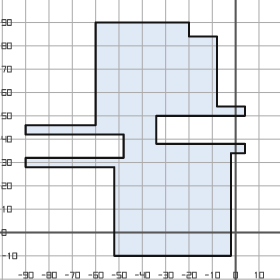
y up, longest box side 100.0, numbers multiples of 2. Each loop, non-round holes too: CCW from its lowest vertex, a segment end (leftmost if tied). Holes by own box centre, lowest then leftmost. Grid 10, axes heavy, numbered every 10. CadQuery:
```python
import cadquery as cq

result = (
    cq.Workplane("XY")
    .moveTo(-52.0, -10.0)
    .lineTo(-2.0, -10.0)
    .lineTo(-2.0, 34.0)
    .lineTo(4.0, 34.0)
    .lineTo(4.0, 38.0)
    .lineTo(-34.0, 38.0)
    .lineTo(-34.0, 50.0)
    .lineTo(4.0, 50.0)
    .lineTo(4.0, 54.0)
    .lineTo(-8.0, 54.0)
    .lineTo(-8.0, 84.0)
    .lineTo(-20.0, 84.0)
    .lineTo(-20.0, 90.0)
    .lineTo(-60.0, 90.0)
    .lineTo(-60.0, 46.0)
    .lineTo(-90.0, 46.0)
    .lineTo(-90.0, 42.0)
    .lineTo(-48.0, 42.0)
    .lineTo(-48.0, 32.0)
    .lineTo(-90.0, 32.0)
    .lineTo(-90.0, 28.0)
    .lineTo(-52.0, 28.0)
    .close()
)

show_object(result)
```